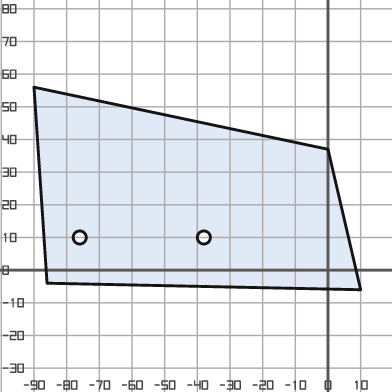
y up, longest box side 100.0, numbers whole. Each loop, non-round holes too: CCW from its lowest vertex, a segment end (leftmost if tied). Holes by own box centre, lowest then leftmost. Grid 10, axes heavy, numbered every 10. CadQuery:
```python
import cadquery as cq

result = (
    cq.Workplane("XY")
    .moveTo(10.0, -6.0)
    .lineTo(0.0, 37.0)
    .lineTo(-90.0, 56.0)
    .lineTo(-86.0, -4.0)
    .close()
    .moveTo(-76.0, 10.0)
    .circle(2.0)
    .moveTo(-38.0, 10.0)
    .circle(2.0)
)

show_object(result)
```